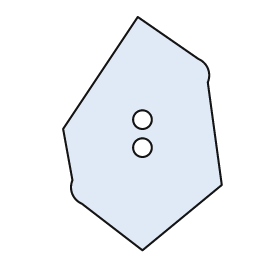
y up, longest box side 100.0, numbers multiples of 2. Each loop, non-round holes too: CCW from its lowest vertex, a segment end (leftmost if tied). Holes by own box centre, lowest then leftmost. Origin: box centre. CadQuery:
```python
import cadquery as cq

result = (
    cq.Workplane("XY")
    .moveTo(0.0, -50.0)
    .lineTo(34.0, -22.0)
    .lineTo(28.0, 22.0)
    .threePointArc((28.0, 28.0), (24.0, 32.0))
    .lineTo(-2.0, 50.0)
    .lineTo(-34.0, 2.0)
    .lineTo(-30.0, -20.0)
    .threePointArc((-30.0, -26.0), (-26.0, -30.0))
    .close()
    .moveTo(0.0, -6.0)
    .circle(4.0)
    .moveTo(0.0, 6.0)
    .circle(4.0)
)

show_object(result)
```